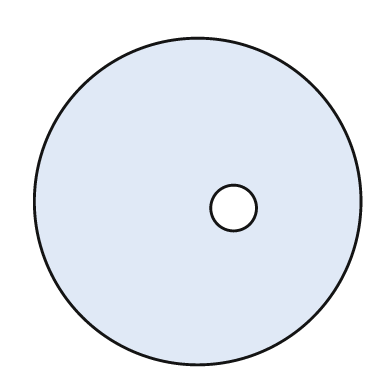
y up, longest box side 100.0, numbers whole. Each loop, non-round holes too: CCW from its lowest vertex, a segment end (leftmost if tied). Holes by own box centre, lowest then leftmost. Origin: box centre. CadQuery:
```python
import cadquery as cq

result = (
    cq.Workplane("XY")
    .moveTo(0.0, 0.0)
    .circle(50.0)
    .moveTo(11.0, -2.0)
    .circle(7.0)
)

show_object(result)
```